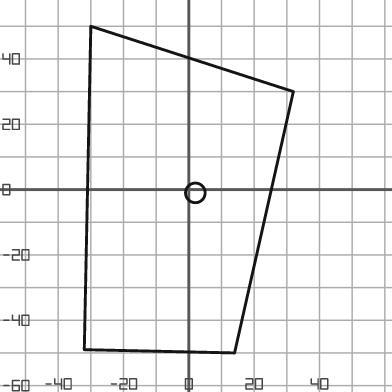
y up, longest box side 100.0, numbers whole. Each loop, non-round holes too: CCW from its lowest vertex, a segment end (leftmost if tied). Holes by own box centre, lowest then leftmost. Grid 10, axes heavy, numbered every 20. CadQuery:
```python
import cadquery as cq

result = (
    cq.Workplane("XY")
    .moveTo(14.0, -50.0)
    .lineTo(32.0, 30.0)
    .lineTo(-30.0, 50.0)
    .lineTo(-32.0, -49.0)
    .close()
    .moveTo(2.0, -1.0)
    .circle(3.0)
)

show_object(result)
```